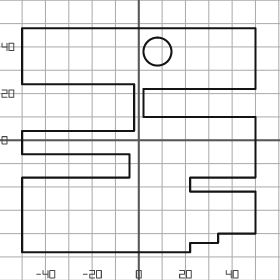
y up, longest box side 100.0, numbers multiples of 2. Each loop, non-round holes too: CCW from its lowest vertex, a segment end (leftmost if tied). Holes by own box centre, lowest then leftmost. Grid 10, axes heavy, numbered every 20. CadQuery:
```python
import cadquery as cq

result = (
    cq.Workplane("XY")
    .moveTo(-50.0, -48.0)
    .lineTo(22.0, -48.0)
    .lineTo(22.0, -44.0)
    .lineTo(34.0, -44.0)
    .lineTo(34.0, -40.0)
    .lineTo(50.0, -40.0)
    .lineTo(50.0, -22.0)
    .lineTo(22.0, -22.0)
    .lineTo(22.0, -16.0)
    .lineTo(50.0, -16.0)
    .lineTo(50.0, 10.0)
    .lineTo(2.0, 10.0)
    .lineTo(2.0, 22.0)
    .lineTo(50.0, 22.0)
    .lineTo(50.0, 48.0)
    .lineTo(-50.0, 48.0)
    .lineTo(-50.0, 24.0)
    .lineTo(-2.0, 24.0)
    .lineTo(-2.0, 4.0)
    .lineTo(-50.0, 4.0)
    .lineTo(-50.0, -6.0)
    .lineTo(-4.0, -6.0)
    .lineTo(-4.0, -16.0)
    .lineTo(-50.0, -16.0)
    .close()
    .moveTo(8.0, 38.0)
    .circle(6.0)
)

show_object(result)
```